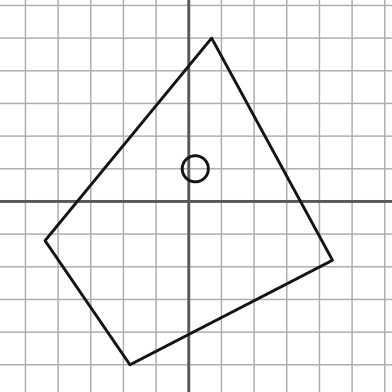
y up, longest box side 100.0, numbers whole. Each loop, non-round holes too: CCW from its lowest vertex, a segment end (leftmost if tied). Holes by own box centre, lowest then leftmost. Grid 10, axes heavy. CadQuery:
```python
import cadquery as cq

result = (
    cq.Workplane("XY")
    .moveTo(-18.0, -50.0)
    .lineTo(44.0, -18.0)
    .lineTo(7.0, 50.0)
    .lineTo(-44.0, -12.0)
    .close()
    .moveTo(2.0, 10.0)
    .circle(4.0)
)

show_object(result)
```